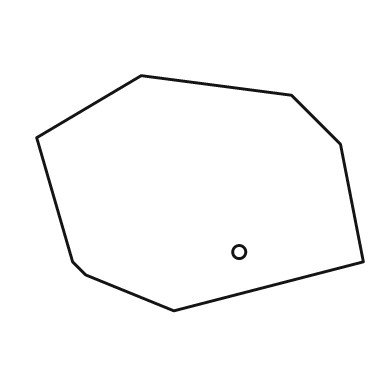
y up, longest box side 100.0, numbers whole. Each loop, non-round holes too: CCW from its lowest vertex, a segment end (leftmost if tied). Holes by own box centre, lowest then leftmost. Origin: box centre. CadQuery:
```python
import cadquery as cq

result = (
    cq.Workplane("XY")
    .moveTo(-8.0, -36.0)
    .lineTo(50.0, -21.0)
    .lineTo(43.0, 15.0)
    .lineTo(28.0, 30.0)
    .lineTo(-18.0, 36.0)
    .lineTo(-50.0, 17.0)
    .lineTo(-39.0, -21.0)
    .lineTo(-35.0, -25.0)
    .close()
    .moveTo(12.0, -18.0)
    .circle(2.0)
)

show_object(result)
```